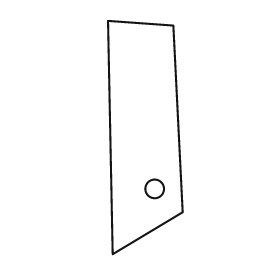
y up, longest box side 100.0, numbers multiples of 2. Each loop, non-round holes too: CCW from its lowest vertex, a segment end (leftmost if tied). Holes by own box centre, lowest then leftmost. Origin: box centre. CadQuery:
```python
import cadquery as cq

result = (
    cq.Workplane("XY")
    .moveTo(-14.0, -50.0)
    .lineTo(16.0, -32.0)
    .lineTo(12.0, 48.0)
    .lineTo(-16.0, 50.0)
    .close()
    .moveTo(4.0, -22.0)
    .circle(4.0)
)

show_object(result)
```